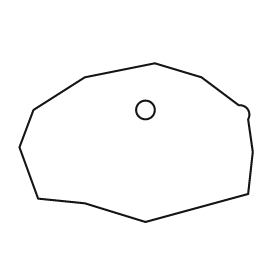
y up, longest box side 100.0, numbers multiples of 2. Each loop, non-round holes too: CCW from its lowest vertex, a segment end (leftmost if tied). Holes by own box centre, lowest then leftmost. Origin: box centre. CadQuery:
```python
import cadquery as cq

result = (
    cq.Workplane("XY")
    .moveTo(4.0, -34.0)
    .lineTo(48.0, -22.0)
    .lineTo(50.0, -4.0)
    .lineTo(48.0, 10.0)
    .threePointArc((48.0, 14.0), (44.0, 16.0))
    .lineTo(28.0, 28.0)
    .lineTo(8.0, 34.0)
    .lineTo(-22.0, 28.0)
    .lineTo(-44.0, 14.0)
    .lineTo(-50.0, -2.0)
    .lineTo(-42.0, -24.0)
    .lineTo(-22.0, -26.0)
    .close()
    .moveTo(4.0, 14.0)
    .circle(4.0)
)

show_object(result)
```